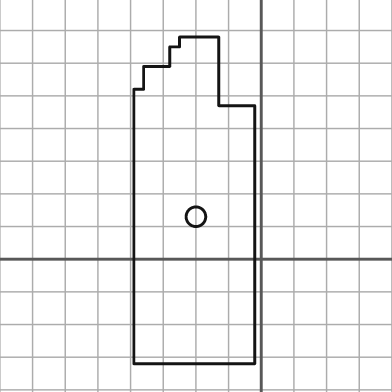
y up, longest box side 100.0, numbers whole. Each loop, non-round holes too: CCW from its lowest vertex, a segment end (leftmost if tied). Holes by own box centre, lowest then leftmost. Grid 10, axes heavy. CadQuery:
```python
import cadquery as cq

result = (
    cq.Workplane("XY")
    .moveTo(-39.0, -32.0)
    .lineTo(-2.0, -32.0)
    .lineTo(-2.0, 47.0)
    .lineTo(-13.0, 47.0)
    .lineTo(-13.0, 68.0)
    .lineTo(-25.0, 68.0)
    .lineTo(-25.0, 65.0)
    .lineTo(-28.0, 65.0)
    .lineTo(-28.0, 59.0)
    .lineTo(-36.0, 59.0)
    .lineTo(-36.0, 52.0)
    .lineTo(-39.0, 52.0)
    .close()
    .moveTo(-20.0, 13.0)
    .circle(3.0)
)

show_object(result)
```